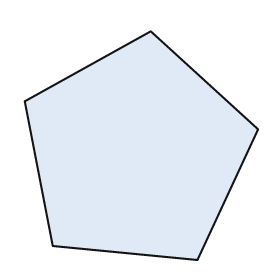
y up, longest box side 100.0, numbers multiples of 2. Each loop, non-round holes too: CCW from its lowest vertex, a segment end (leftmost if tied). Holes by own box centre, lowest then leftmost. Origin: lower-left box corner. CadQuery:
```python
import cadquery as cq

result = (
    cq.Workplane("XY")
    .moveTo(74.0, 0.0)
    .lineTo(100.0, 56.0)
    .lineTo(54.0, 98.0)
    .lineTo(0.0, 68.0)
    .lineTo(12.0, 6.0)
    .close()
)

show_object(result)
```